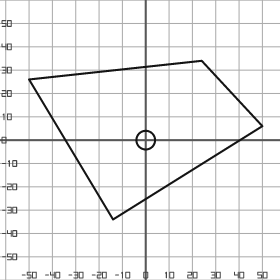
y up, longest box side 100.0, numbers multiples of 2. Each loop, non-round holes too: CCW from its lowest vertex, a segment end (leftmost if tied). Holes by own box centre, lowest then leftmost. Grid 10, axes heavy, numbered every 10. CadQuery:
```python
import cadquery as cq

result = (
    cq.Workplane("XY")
    .moveTo(-14.0, -34.0)
    .lineTo(50.0, 6.0)
    .lineTo(24.0, 34.0)
    .lineTo(-50.0, 26.0)
    .close()
    .moveTo(0.0, 0.0)
    .circle(4.0)
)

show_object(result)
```